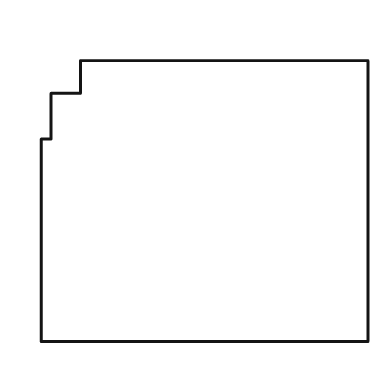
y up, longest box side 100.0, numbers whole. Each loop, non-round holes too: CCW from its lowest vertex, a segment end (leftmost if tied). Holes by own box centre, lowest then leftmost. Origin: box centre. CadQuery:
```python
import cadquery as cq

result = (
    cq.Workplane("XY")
    .moveTo(-50.0, -43.0)
    .lineTo(50.0, -43.0)
    .lineTo(50.0, 43.0)
    .lineTo(-38.0, 43.0)
    .lineTo(-38.0, 33.0)
    .lineTo(-47.0, 33.0)
    .lineTo(-47.0, 19.0)
    .lineTo(-50.0, 19.0)
    .close()
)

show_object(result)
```